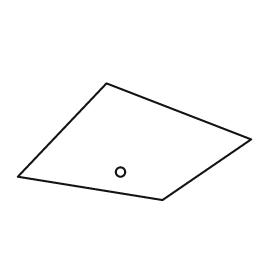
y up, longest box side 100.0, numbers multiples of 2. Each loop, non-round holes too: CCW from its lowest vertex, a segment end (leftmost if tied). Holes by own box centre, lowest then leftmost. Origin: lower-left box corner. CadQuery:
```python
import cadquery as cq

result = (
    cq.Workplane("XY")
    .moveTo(62.0, 0.0)
    .lineTo(100.0, 26.0)
    .lineTo(38.0, 50.0)
    .lineTo(0.0, 10.0)
    .close()
    .moveTo(44.0, 12.0)
    .circle(2.0)
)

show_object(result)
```